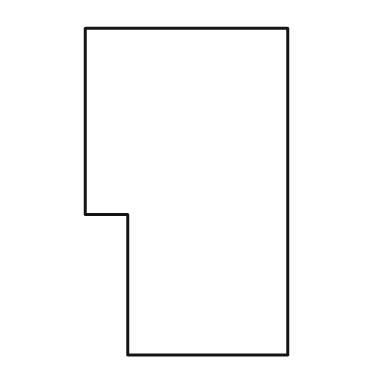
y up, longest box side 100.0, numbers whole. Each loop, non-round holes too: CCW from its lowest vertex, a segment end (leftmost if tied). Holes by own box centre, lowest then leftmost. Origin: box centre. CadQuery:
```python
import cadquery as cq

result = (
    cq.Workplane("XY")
    .moveTo(-18.0, -50.0)
    .lineTo(31.0, -50.0)
    .lineTo(31.0, 50.0)
    .lineTo(-31.0, 50.0)
    .lineTo(-31.0, -7.0)
    .lineTo(-18.0, -7.0)
    .close()
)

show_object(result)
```